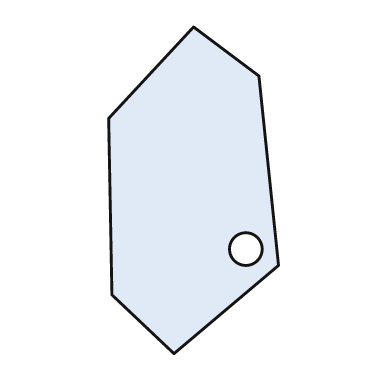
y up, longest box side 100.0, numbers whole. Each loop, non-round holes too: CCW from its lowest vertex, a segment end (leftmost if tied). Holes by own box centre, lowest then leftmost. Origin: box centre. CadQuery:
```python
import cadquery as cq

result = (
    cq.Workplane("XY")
    .moveTo(-6.0, -50.0)
    .lineTo(26.0, -23.0)
    .lineTo(20.0, 35.0)
    .lineTo(0.0, 50.0)
    .lineTo(-26.0, 22.0)
    .lineTo(-25.0, -32.0)
    .close()
    .moveTo(16.0, -18.0)
    .circle(5.0)
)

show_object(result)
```